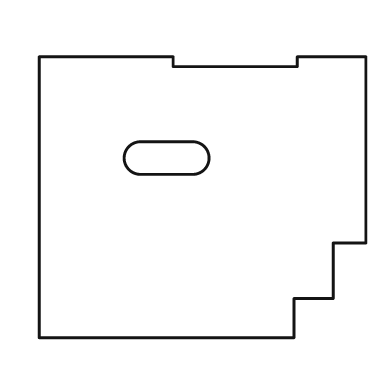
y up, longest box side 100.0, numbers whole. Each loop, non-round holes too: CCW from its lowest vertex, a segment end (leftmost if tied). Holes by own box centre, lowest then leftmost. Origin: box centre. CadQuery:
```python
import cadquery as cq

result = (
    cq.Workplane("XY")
    .moveTo(-50.0, -43.0)
    .lineTo(28.0, -43.0)
    .lineTo(28.0, -31.0)
    .lineTo(40.0, -31.0)
    .lineTo(40.0, -14.0)
    .lineTo(50.0, -14.0)
    .lineTo(50.0, 43.0)
    .lineTo(29.0, 43.0)
    .lineTo(29.0, 40.0)
    .lineTo(-9.0, 40.0)
    .lineTo(-9.0, 43.0)
    .lineTo(-50.0, 43.0)
    .close()
    .moveTo(-19.0, 7.0)
    .lineTo(-3.0, 7.0)
    .threePointArc((2.0, 12.0), (-3.0, 17.0))
    .lineTo(-19.0, 17.0)
    .threePointArc((-24.0, 12.0), (-19.0, 7.0))
    .close()
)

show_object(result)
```